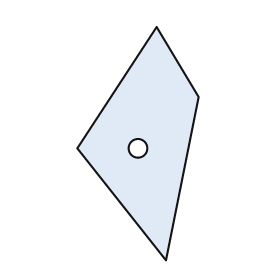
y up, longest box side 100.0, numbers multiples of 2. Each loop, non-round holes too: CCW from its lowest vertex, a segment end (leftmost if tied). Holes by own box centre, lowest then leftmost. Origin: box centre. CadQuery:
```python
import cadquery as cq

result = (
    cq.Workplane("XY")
    .moveTo(12.0, -50.0)
    .lineTo(26.0, 20.0)
    .lineTo(8.0, 50.0)
    .lineTo(-26.0, -2.0)
    .close()
    .moveTo(0.0, -2.0)
    .circle(4.0)
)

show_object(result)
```